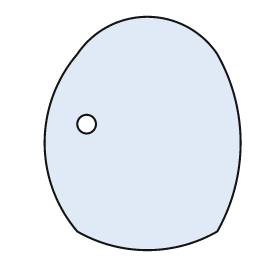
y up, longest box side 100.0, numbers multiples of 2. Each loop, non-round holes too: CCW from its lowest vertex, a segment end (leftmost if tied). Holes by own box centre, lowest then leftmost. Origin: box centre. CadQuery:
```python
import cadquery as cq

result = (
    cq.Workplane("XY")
    .moveTo(-28.0, -42.0)
    .threePointArc((2.0, -50.0), (32.0, -42.0))
    .threePointArc((42.0, -4.0), (32.0, 34.0))
    .threePointArc((2.0, 50.0), (-28.0, 34.0))
    .threePointArc((-42.0, -4.0), (-28.0, -42.0))
    .close()
    .moveTo(-24.0, 4.0)
    .circle(4.0)
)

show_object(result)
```